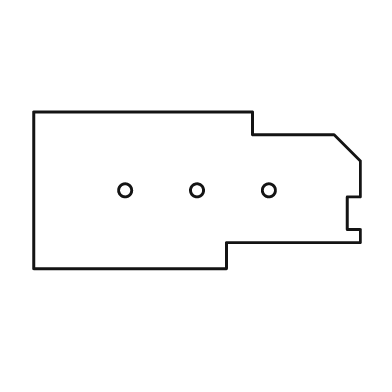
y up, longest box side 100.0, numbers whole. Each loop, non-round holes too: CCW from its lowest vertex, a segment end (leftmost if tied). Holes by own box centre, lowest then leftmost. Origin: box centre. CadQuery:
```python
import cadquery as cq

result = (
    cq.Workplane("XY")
    .moveTo(-50.0, -24.0)
    .lineTo(9.0, -24.0)
    .lineTo(9.0, -16.0)
    .lineTo(50.0, -16.0)
    .lineTo(50.0, -12.0)
    .lineTo(46.0, -12.0)
    .lineTo(46.0, -2.0)
    .lineTo(50.0, -2.0)
    .lineTo(50.0, 9.0)
    .lineTo(42.0, 17.0)
    .lineTo(17.0, 17.0)
    .lineTo(17.0, 24.0)
    .lineTo(-50.0, 24.0)
    .close()
    .moveTo(-22.0, 0.0)
    .circle(2.0)
    .moveTo(0.0, 0.0)
    .circle(2.0)
    .moveTo(22.0, 0.0)
    .circle(2.0)
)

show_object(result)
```